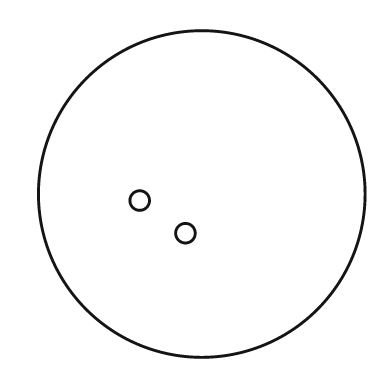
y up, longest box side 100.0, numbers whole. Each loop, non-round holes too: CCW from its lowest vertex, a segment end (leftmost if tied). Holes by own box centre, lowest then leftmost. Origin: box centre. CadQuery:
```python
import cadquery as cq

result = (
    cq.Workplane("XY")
    .moveTo(0.0, 0.0)
    .circle(50.0)
    .moveTo(-5.0, -12.0)
    .circle(3.0)
    .moveTo(-19.0, -2.0)
    .circle(3.0)
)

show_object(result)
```